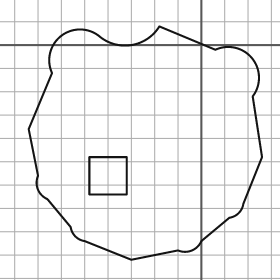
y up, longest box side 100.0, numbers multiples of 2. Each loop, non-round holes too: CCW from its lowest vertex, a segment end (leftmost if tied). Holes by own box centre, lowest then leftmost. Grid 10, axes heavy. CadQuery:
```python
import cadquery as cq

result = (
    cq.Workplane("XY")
    .moveTo(-30.0, -92.0)
    .lineTo(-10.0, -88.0)
    .threePointArc((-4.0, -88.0), (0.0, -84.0))
    .lineTo(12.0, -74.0)
    .threePointArc((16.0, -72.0), (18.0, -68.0))
    .lineTo(26.0, -48.0)
    .lineTo(22.0, -22.0)
    .threePointArc((22.0, -6.0), (6.0, -2.0))
    .lineTo(-18.0, 8.0)
    .threePointArc((-30.0, 0.0), (-44.0, 4.0))
    .threePointArc((-60.0, 4.0), (-64.0, -12.0))
    .lineTo(-74.0, -36.0)
    .lineTo(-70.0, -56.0)
    .threePointArc((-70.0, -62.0), (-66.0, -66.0))
    .lineTo(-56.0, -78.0)
    .threePointArc((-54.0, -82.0), (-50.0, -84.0))
    .close()
    .moveTo(-48.0, -64.0)
    .lineTo(-32.0, -64.0)
    .lineTo(-32.0, -48.0)
    .lineTo(-48.0, -48.0)
    .close()
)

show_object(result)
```